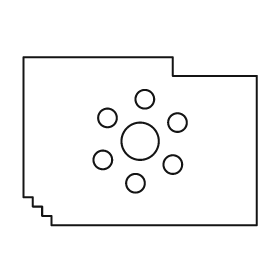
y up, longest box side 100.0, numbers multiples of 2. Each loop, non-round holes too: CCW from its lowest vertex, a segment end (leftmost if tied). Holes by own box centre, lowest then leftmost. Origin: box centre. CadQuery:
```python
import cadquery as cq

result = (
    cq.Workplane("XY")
    .moveTo(-38.0, -36.0)
    .lineTo(50.0, -36.0)
    .lineTo(50.0, 28.0)
    .lineTo(14.0, 28.0)
    .lineTo(14.0, 36.0)
    .lineTo(-50.0, 36.0)
    .lineTo(-50.0, -24.0)
    .lineTo(-46.0, -24.0)
    .lineTo(-46.0, -28.0)
    .lineTo(-42.0, -28.0)
    .lineTo(-42.0, -32.0)
    .lineTo(-38.0, -32.0)
    .close()
    .moveTo(-2.0, -18.0)
    .circle(4.0)
    .moveTo(14.0, -10.0)
    .circle(4.0)
    .moveTo(-16.0, -8.0)
    .circle(4.0)
    .moveTo(0.0, 0.0)
    .circle(8.0)
    .moveTo(16.0, 8.0)
    .circle(4.0)
    .moveTo(-14.0, 10.0)
    .circle(4.0)
    .moveTo(2.0, 18.0)
    .circle(4.0)
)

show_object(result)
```